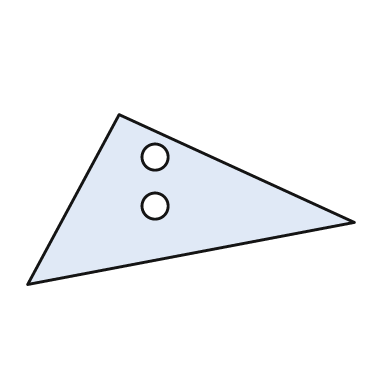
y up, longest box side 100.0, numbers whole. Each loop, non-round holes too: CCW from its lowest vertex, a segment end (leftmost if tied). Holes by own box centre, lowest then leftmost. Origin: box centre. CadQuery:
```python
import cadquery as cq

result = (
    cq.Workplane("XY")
    .moveTo(-50.0, -26.0)
    .lineTo(50.0, -7.0)
    .lineTo(-22.0, 26.0)
    .close()
    .moveTo(-11.0, -2.0)
    .circle(4.0)
    .moveTo(-11.0, 13.0)
    .circle(4.0)
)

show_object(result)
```